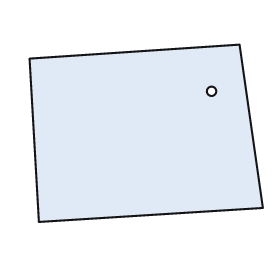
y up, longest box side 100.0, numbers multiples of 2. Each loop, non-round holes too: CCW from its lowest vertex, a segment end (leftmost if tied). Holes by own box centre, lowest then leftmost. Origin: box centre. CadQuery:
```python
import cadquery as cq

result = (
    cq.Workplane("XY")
    .moveTo(-46.0, -38.0)
    .lineTo(50.0, -32.0)
    .lineTo(40.0, 38.0)
    .lineTo(-50.0, 32.0)
    .close()
    .moveTo(28.0, 18.0)
    .circle(2.0)
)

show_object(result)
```